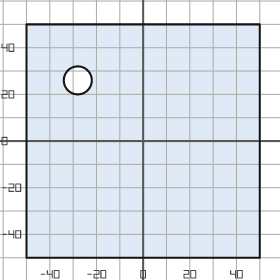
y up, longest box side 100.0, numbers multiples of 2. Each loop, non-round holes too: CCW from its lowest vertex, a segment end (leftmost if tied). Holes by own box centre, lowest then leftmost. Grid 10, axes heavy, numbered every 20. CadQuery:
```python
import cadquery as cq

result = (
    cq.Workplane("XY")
    .moveTo(-50.0, -50.0)
    .lineTo(50.0, -50.0)
    .lineTo(50.0, 50.0)
    .lineTo(-50.0, 50.0)
    .close()
    .moveTo(-28.0, 26.0)
    .circle(6.0)
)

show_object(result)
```